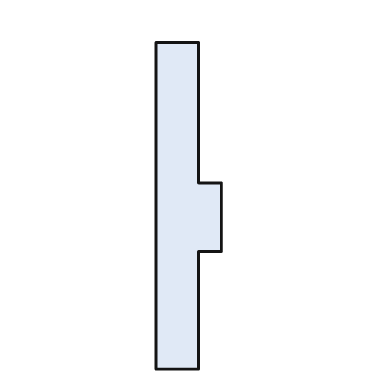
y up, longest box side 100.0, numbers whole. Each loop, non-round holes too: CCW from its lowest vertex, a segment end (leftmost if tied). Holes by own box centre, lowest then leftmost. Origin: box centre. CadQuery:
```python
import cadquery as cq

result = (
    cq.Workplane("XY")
    .moveTo(-10.0, -50.0)
    .lineTo(3.0, -50.0)
    .lineTo(3.0, -14.0)
    .lineTo(10.0, -14.0)
    .lineTo(10.0, 7.0)
    .lineTo(3.0, 7.0)
    .lineTo(3.0, 50.0)
    .lineTo(-10.0, 50.0)
    .close()
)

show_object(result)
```